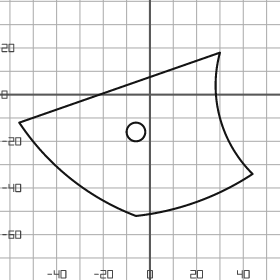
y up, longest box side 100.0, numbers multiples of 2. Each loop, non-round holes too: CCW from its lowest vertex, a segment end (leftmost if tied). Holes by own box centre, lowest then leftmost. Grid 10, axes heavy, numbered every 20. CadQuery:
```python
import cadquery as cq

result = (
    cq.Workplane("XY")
    .moveTo(-6.0, -52.0)
    .threePointArc((20.0, -46.0), (44.0, -34.0))
    .threePointArc((30.0, -10.0), (30.0, 18.0))
    .lineTo(-56.0, -12.0)
    .threePointArc((-34.0, -36.0), (-6.0, -52.0))
    .close()
    .moveTo(-6.0, -16.0)
    .circle(4.0)
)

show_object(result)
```